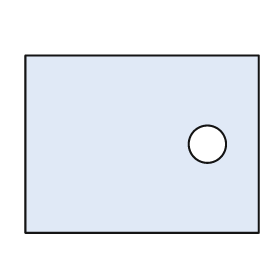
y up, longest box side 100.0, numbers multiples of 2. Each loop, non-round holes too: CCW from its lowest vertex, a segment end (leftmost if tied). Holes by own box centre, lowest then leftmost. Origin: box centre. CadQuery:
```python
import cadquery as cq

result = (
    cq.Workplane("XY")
    .moveTo(-50.0, -38.0)
    .lineTo(50.0, -38.0)
    .lineTo(50.0, 38.0)
    .lineTo(-50.0, 38.0)
    .close()
    .moveTo(28.0, 0.0)
    .circle(8.0)
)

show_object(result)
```